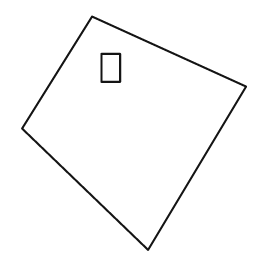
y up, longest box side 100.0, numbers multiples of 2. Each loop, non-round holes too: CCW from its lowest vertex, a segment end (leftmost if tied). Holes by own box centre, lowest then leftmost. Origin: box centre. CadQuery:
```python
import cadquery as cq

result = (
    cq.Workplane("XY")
    .moveTo(6.0, -50.0)
    .lineTo(48.0, 20.0)
    .lineTo(-18.0, 50.0)
    .lineTo(-48.0, 2.0)
    .close()
    .moveTo(-14.0, 22.0)
    .lineTo(-6.0, 22.0)
    .lineTo(-6.0, 34.0)
    .lineTo(-14.0, 34.0)
    .close()
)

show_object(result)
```